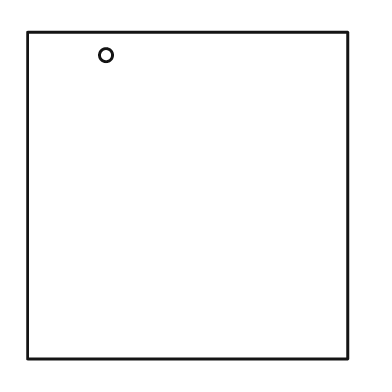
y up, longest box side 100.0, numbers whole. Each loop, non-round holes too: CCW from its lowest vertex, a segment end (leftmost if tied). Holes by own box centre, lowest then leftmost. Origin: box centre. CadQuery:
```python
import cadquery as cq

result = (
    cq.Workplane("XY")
    .moveTo(-49.0, -50.0)
    .lineTo(49.0, -50.0)
    .lineTo(49.0, 50.0)
    .lineTo(-49.0, 50.0)
    .close()
    .moveTo(-25.0, 43.0)
    .circle(2.0)
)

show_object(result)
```